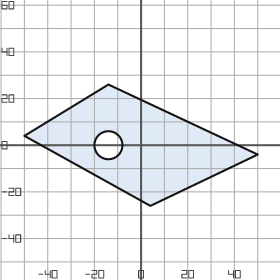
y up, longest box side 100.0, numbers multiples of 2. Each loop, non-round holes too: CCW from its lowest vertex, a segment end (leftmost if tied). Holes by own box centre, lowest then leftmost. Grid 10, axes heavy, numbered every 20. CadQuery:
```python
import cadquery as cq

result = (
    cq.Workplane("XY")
    .moveTo(4.0, -26.0)
    .lineTo(50.0, -4.0)
    .lineTo(-14.0, 26.0)
    .lineTo(-50.0, 4.0)
    .close()
    .moveTo(-14.0, 0.0)
    .circle(6.0)
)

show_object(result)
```